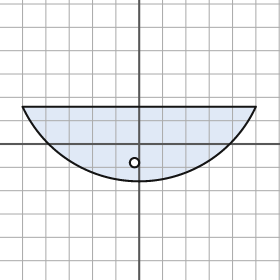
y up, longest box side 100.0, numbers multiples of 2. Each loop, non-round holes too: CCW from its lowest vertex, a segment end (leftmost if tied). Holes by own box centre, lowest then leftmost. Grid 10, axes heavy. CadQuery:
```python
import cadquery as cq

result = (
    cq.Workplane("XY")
    .moveTo(-50.0, 16.0)
    .threePointArc((0.0, -16.0), (50.0, 16.0))
    .close()
    .moveTo(-2.0, -8.0)
    .circle(2.0)
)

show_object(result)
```